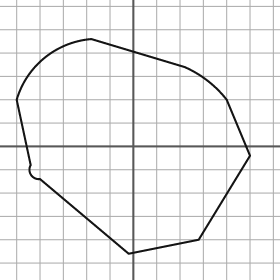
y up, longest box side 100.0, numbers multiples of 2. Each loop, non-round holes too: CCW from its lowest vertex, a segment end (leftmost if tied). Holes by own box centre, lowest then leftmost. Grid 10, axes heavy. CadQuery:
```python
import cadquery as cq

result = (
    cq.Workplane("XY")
    .moveTo(-2.0, -46.0)
    .lineTo(28.0, -40.0)
    .lineTo(50.0, -4.0)
    .lineTo(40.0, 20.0)
    .threePointArc((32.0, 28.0), (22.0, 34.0))
    .lineTo(-18.0, 46.0)
    .threePointArc((-38.0, 38.0), (-50.0, 20.0))
    .lineTo(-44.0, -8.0)
    .threePointArc((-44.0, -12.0), (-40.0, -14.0))
    .close()
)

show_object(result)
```